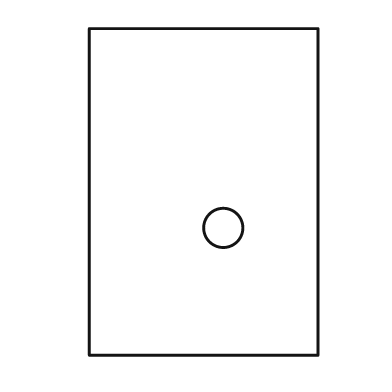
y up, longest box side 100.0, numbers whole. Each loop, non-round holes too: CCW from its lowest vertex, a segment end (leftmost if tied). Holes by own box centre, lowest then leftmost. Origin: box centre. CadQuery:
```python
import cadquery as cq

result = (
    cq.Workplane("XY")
    .moveTo(-35.0, -50.0)
    .lineTo(35.0, -50.0)
    .lineTo(35.0, 50.0)
    .lineTo(-35.0, 50.0)
    .close()
    .moveTo(6.0, -11.0)
    .circle(6.0)
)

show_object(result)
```